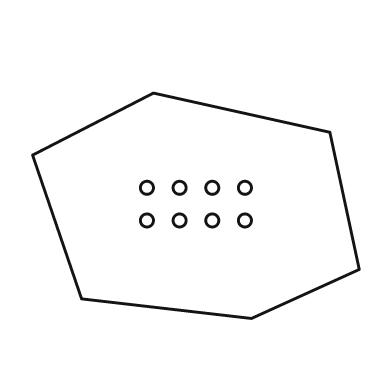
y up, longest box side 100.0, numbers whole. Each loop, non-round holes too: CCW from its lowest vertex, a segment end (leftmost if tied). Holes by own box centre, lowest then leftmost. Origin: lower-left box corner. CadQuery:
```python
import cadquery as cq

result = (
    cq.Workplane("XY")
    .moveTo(67.0, 0.0)
    .lineTo(100.0, 15.0)
    .lineTo(91.0, 57.0)
    .lineTo(37.0, 69.0)
    .lineTo(0.0, 50.0)
    .lineTo(15.0, 6.0)
    .close()
    .moveTo(35.0, 30.0)
    .circle(2.0)
    .moveTo(45.0, 30.0)
    .circle(2.0)
    .moveTo(55.0, 30.0)
    .circle(2.0)
    .moveTo(65.0, 30.0)
    .circle(2.0)
    .moveTo(35.0, 40.0)
    .circle(2.0)
    .moveTo(45.0, 40.0)
    .circle(2.0)
    .moveTo(55.0, 40.0)
    .circle(2.0)
    .moveTo(65.0, 40.0)
    .circle(2.0)
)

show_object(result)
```